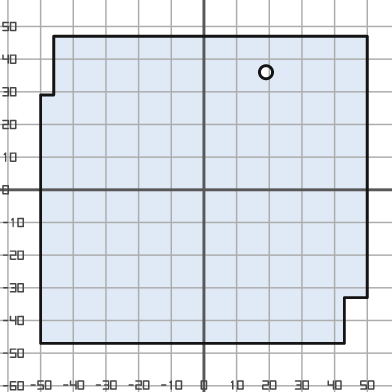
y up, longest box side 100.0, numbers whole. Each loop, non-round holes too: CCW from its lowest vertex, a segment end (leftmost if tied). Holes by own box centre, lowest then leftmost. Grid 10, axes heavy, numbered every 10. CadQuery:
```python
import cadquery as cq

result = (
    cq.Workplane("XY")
    .moveTo(-50.0, -47.0)
    .lineTo(43.0, -47.0)
    .lineTo(43.0, -33.0)
    .lineTo(50.0, -33.0)
    .lineTo(50.0, 47.0)
    .lineTo(-46.0, 47.0)
    .lineTo(-46.0, 29.0)
    .lineTo(-50.0, 29.0)
    .close()
    .moveTo(19.0, 36.0)
    .circle(2.0)
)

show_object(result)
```